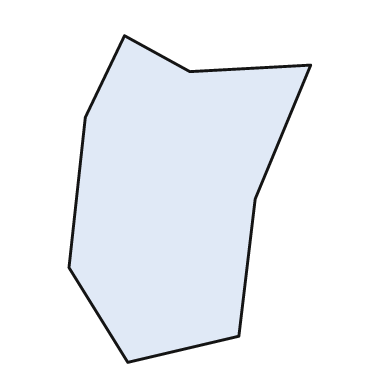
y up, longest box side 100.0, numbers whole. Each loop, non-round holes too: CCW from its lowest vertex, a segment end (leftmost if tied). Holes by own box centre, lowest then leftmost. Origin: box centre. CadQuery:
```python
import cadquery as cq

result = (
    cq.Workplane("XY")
    .moveTo(-19.0, -50.0)
    .lineTo(15.0, -42.0)
    .lineTo(20.0, 0.0)
    .lineTo(37.0, 41.0)
    .lineTo(0.0, 39.0)
    .lineTo(-20.0, 50.0)
    .lineTo(-32.0, 25.0)
    .lineTo(-37.0, -21.0)
    .close()
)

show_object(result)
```